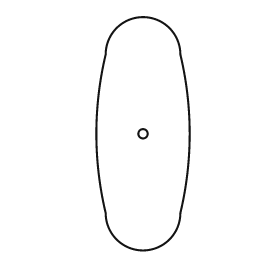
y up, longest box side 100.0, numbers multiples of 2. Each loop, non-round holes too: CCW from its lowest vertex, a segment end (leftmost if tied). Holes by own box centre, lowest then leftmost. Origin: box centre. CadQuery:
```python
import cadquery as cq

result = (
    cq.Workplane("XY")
    .moveTo(-16.0, -34.0)
    .threePointArc((0.0, -50.0), (16.0, -34.0))
    .threePointArc((20.0, 0.0), (16.0, 34.0))
    .threePointArc((0.0, 50.0), (-16.0, 34.0))
    .threePointArc((-20.0, 0.0), (-16.0, -34.0))
    .close()
    .moveTo(0.0, 0.0)
    .circle(2.0)
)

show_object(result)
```